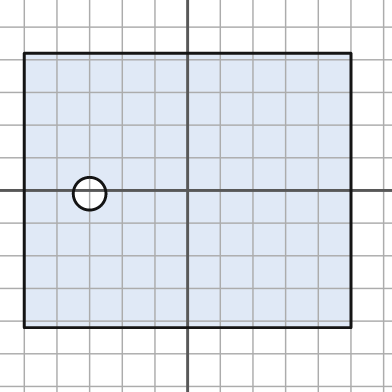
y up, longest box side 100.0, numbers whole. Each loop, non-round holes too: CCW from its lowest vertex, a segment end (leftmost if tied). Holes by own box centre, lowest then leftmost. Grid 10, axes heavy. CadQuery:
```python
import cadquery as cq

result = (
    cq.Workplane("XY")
    .moveTo(-50.0, -42.0)
    .lineTo(50.0, -42.0)
    .lineTo(50.0, 42.0)
    .lineTo(-50.0, 42.0)
    .close()
    .moveTo(-30.0, -1.0)
    .circle(5.0)
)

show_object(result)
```